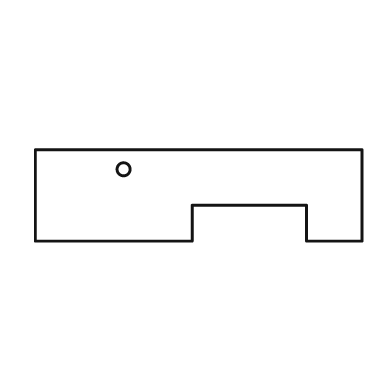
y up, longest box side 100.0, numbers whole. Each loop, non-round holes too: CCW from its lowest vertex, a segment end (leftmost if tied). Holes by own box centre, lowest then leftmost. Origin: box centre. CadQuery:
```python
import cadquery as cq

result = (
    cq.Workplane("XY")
    .moveTo(-50.0, -14.0)
    .lineTo(-2.0, -14.0)
    .lineTo(-2.0, -3.0)
    .lineTo(33.0, -3.0)
    .lineTo(33.0, -14.0)
    .lineTo(50.0, -14.0)
    .lineTo(50.0, 14.0)
    .lineTo(-50.0, 14.0)
    .close()
    .moveTo(-23.0, 8.0)
    .circle(2.0)
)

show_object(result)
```